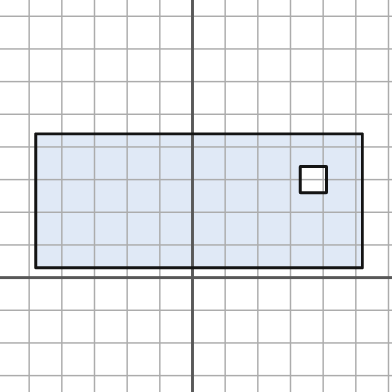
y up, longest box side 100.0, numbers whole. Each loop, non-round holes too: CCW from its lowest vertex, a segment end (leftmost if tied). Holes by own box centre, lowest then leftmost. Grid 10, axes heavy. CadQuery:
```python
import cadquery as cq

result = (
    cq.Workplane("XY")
    .moveTo(-48.0, 3.0)
    .lineTo(52.0, 3.0)
    .lineTo(52.0, 44.0)
    .lineTo(-48.0, 44.0)
    .close()
    .moveTo(33.0, 26.0)
    .lineTo(41.0, 26.0)
    .lineTo(41.0, 34.0)
    .lineTo(33.0, 34.0)
    .close()
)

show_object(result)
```